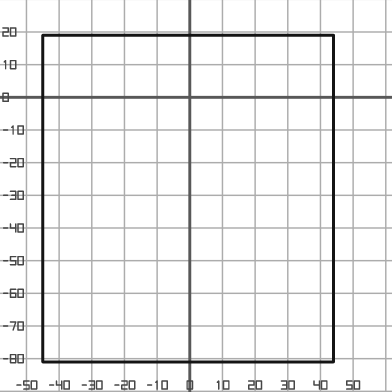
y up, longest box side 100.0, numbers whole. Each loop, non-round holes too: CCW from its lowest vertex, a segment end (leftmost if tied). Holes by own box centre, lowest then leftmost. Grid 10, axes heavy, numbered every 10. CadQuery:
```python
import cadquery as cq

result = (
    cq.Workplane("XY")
    .moveTo(-45.0, -81.0)
    .lineTo(44.0, -81.0)
    .lineTo(44.0, 19.0)
    .lineTo(-45.0, 19.0)
    .close()
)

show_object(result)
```